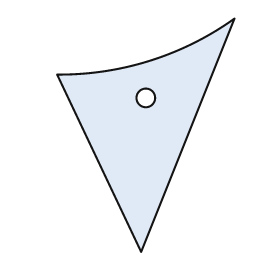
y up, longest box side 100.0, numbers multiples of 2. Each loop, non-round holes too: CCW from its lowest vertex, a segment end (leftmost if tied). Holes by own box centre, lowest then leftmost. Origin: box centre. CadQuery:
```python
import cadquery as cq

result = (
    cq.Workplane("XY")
    .moveTo(-2.0, -50.0)
    .lineTo(38.0, 50.0)
    .threePointArc((2.0, 32.0), (-38.0, 26.0))
    .close()
    .moveTo(0.0, 16.0)
    .circle(4.0)
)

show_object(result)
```